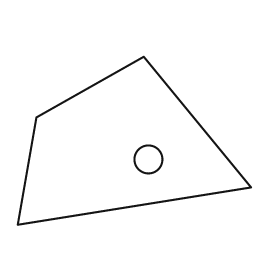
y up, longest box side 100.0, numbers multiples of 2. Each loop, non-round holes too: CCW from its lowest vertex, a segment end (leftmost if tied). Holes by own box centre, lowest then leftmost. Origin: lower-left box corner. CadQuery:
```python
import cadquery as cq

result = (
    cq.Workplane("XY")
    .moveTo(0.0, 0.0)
    .lineTo(100.0, 16.0)
    .lineTo(54.0, 72.0)
    .lineTo(8.0, 46.0)
    .close()
    .moveTo(56.0, 28.0)
    .circle(6.0)
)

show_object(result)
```